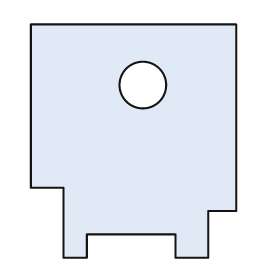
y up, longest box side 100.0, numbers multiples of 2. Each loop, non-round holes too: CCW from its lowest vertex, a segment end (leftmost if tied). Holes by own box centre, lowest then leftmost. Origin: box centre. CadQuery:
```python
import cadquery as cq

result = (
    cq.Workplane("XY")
    .moveTo(-30.0, -50.0)
    .lineTo(-20.0, -50.0)
    .lineTo(-20.0, -40.0)
    .lineTo(18.0, -40.0)
    .lineTo(18.0, -50.0)
    .lineTo(32.0, -50.0)
    .lineTo(32.0, -30.0)
    .lineTo(44.0, -30.0)
    .lineTo(44.0, 50.0)
    .lineTo(-44.0, 50.0)
    .lineTo(-44.0, -20.0)
    .lineTo(-30.0, -20.0)
    .close()
    .moveTo(4.0, 24.0)
    .circle(10.0)
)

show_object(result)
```